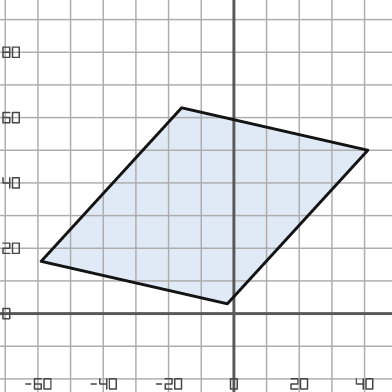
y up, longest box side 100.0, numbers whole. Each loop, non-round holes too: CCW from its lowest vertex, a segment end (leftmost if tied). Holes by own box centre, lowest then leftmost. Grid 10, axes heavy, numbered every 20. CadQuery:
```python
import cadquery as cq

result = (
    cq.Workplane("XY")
    .moveTo(-2.0, 3.0)
    .lineTo(41.0, 50.0)
    .lineTo(-16.0, 63.0)
    .lineTo(-59.0, 16.0)
    .close()
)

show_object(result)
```